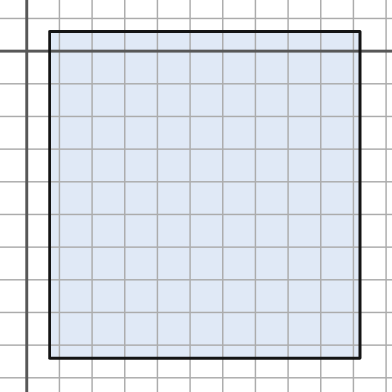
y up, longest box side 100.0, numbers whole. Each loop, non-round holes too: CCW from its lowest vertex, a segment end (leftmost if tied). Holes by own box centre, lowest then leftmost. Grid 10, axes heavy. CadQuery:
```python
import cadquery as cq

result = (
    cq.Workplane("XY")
    .moveTo(7.0, -94.0)
    .lineTo(102.0, -94.0)
    .lineTo(102.0, 6.0)
    .lineTo(7.0, 6.0)
    .close()
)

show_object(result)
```